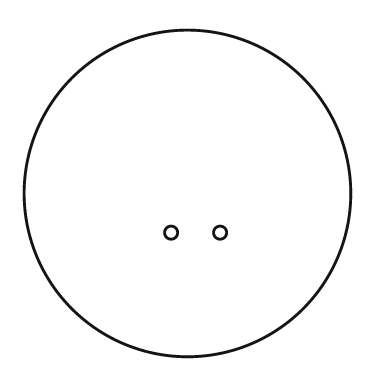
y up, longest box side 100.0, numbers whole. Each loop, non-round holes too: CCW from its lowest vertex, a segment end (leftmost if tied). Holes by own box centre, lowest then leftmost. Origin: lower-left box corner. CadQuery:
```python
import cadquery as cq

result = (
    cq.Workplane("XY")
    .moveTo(50.0, 50.0)
    .circle(50.0)
    .moveTo(45.0, 38.0)
    .circle(2.0)
    .moveTo(60.0, 38.0)
    .circle(2.0)
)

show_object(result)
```